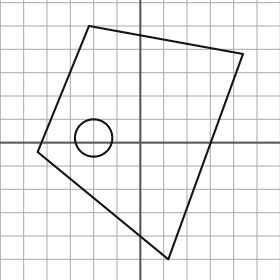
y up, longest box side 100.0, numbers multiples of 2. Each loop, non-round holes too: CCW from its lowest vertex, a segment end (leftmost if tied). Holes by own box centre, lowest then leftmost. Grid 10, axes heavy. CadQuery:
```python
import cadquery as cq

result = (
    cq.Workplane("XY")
    .moveTo(12.0, -50.0)
    .lineTo(44.0, 38.0)
    .lineTo(-22.0, 50.0)
    .lineTo(-44.0, -4.0)
    .close()
    .moveTo(-20.0, 2.0)
    .circle(8.0)
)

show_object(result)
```